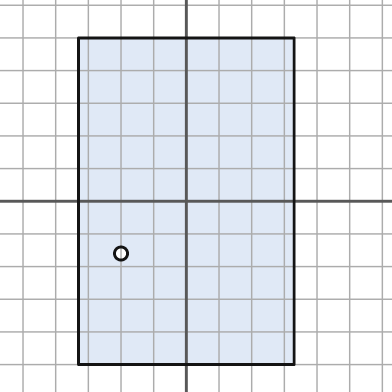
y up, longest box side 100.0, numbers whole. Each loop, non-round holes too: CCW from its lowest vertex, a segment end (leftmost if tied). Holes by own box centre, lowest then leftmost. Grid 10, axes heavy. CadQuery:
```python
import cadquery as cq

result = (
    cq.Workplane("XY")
    .moveTo(-33.0, -50.0)
    .lineTo(33.0, -50.0)
    .lineTo(33.0, 50.0)
    .lineTo(-33.0, 50.0)
    .close()
    .moveTo(-20.0, -16.0)
    .circle(2.0)
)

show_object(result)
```